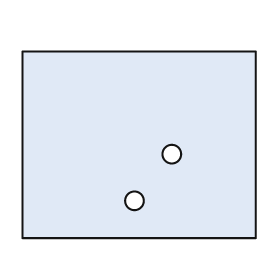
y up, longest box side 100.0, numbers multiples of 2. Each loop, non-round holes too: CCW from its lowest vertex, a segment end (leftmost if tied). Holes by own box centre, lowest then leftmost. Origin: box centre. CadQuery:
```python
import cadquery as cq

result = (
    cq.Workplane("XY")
    .moveTo(-50.0, -40.0)
    .lineTo(50.0, -40.0)
    .lineTo(50.0, 40.0)
    .lineTo(-50.0, 40.0)
    .close()
    .moveTo(-2.0, -24.0)
    .circle(4.0)
    .moveTo(14.0, -4.0)
    .circle(4.0)
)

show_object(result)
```